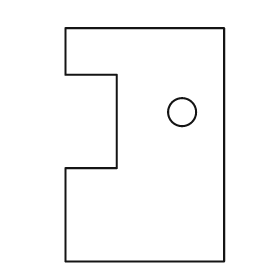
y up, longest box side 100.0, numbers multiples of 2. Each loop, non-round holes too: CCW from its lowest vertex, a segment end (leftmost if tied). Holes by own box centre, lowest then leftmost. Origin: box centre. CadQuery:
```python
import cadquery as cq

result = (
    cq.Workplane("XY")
    .moveTo(-34.0, -50.0)
    .lineTo(34.0, -50.0)
    .lineTo(34.0, 50.0)
    .lineTo(-34.0, 50.0)
    .lineTo(-34.0, 30.0)
    .lineTo(-12.0, 30.0)
    .lineTo(-12.0, -10.0)
    .lineTo(-34.0, -10.0)
    .close()
    .moveTo(16.0, 14.0)
    .circle(6.0)
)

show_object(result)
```